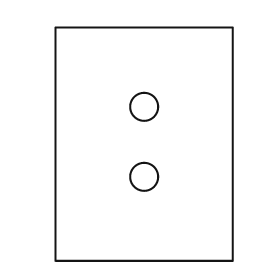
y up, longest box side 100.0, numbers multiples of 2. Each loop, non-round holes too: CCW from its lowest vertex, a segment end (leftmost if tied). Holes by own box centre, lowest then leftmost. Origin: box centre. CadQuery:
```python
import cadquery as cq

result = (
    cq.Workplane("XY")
    .moveTo(-38.0, -50.0)
    .lineTo(38.0, -50.0)
    .lineTo(38.0, 50.0)
    .lineTo(-38.0, 50.0)
    .close()
    .moveTo(0.0, -14.0)
    .circle(6.0)
    .moveTo(0.0, 16.0)
    .circle(6.0)
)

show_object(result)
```